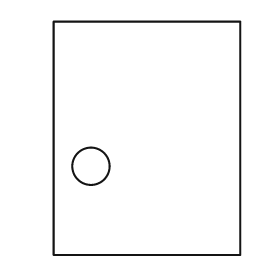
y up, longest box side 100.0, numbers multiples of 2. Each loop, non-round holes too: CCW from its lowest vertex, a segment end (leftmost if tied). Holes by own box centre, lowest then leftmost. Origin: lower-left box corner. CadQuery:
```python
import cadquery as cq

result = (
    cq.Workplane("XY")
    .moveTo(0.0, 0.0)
    .lineTo(80.0, 0.0)
    .lineTo(80.0, 100.0)
    .lineTo(0.0, 100.0)
    .close()
    .moveTo(16.0, 38.0)
    .circle(8.0)
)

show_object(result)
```